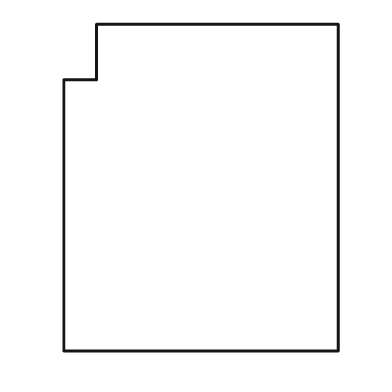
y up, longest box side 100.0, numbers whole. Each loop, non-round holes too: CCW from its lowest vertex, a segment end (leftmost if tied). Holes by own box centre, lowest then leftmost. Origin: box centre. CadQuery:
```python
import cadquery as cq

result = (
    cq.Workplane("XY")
    .moveTo(-42.0, -50.0)
    .lineTo(42.0, -50.0)
    .lineTo(42.0, 50.0)
    .lineTo(-32.0, 50.0)
    .lineTo(-32.0, 33.0)
    .lineTo(-42.0, 33.0)
    .close()
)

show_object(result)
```